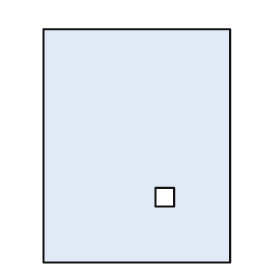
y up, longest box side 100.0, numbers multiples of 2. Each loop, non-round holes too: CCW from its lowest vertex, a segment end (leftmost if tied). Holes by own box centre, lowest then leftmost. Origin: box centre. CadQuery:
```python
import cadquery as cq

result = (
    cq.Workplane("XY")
    .moveTo(-40.0, -50.0)
    .lineTo(40.0, -50.0)
    .lineTo(40.0, 50.0)
    .lineTo(-40.0, 50.0)
    .close()
    .moveTo(8.0, -26.0)
    .lineTo(16.0, -26.0)
    .lineTo(16.0, -18.0)
    .lineTo(8.0, -18.0)
    .close()
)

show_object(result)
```